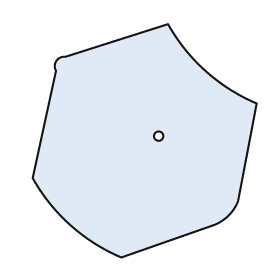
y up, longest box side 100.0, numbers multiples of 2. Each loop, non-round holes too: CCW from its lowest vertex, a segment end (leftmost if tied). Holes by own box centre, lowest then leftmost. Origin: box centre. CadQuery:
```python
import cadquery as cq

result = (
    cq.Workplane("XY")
    .moveTo(-10.0, -50.0)
    .lineTo(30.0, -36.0)
    .threePointArc((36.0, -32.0), (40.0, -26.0))
    .lineTo(48.0, 16.0)
    .threePointArc((26.0, 30.0), (10.0, 50.0))
    .lineTo(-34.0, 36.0)
    .threePointArc((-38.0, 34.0), (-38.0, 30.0))
    .lineTo(-48.0, -16.0)
    .threePointArc((-32.0, -36.0), (-10.0, -50.0))
    .close()
    .moveTo(6.0, 2.0)
    .circle(2.0)
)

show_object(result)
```